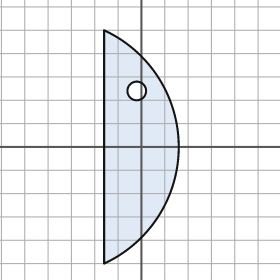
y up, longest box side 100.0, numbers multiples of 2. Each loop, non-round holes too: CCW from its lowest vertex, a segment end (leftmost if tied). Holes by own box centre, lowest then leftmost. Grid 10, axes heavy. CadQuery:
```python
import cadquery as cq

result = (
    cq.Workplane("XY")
    .moveTo(-16.0, -50.0)
    .threePointArc((16.0, 0.0), (-16.0, 50.0))
    .close()
    .moveTo(-2.0, 24.0)
    .circle(4.0)
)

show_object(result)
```